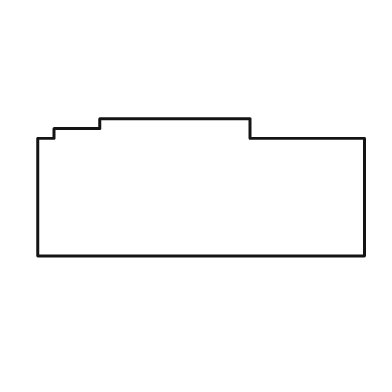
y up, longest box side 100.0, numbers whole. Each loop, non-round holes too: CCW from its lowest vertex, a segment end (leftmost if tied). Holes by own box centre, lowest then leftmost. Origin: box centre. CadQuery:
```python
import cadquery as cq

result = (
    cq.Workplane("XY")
    .moveTo(-50.0, -21.0)
    .lineTo(50.0, -21.0)
    .lineTo(50.0, 15.0)
    .lineTo(15.0, 15.0)
    .lineTo(15.0, 21.0)
    .lineTo(-31.0, 21.0)
    .lineTo(-31.0, 18.0)
    .lineTo(-45.0, 18.0)
    .lineTo(-45.0, 15.0)
    .lineTo(-50.0, 15.0)
    .close()
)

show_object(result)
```